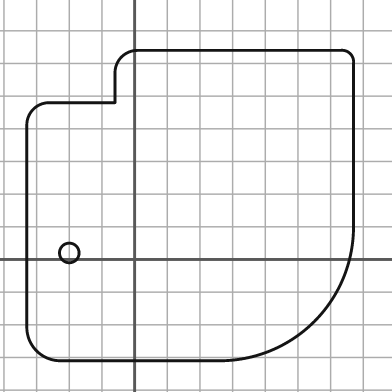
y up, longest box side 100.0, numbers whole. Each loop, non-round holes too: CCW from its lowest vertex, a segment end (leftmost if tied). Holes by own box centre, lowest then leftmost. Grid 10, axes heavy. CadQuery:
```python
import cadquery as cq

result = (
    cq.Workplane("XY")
    .moveTo(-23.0, -31.0)
    .lineTo(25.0, -31.0)
    .threePointArc((55.0, -19.0), (67.0, 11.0))
    .lineTo(67.0, 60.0)
    .threePointArc((66.0, 63.0), (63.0, 64.0))
    .lineTo(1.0, 64.0)
    .threePointArc((-4.0, 62.0), (-6.0, 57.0))
    .lineTo(-6.0, 48.0)
    .lineTo(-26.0, 48.0)
    .threePointArc((-31.0, 46.0), (-33.0, 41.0))
    .lineTo(-33.0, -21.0)
    .threePointArc((-30.0, -28.0), (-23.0, -31.0))
    .close()
    .moveTo(-20.0, 2.0)
    .circle(3.0)
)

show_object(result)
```